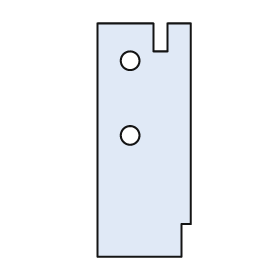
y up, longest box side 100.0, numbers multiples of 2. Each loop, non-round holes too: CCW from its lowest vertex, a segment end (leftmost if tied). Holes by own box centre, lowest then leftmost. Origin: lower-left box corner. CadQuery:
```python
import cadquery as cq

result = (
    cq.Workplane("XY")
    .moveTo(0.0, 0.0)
    .lineTo(36.0, 0.0)
    .lineTo(36.0, 14.0)
    .lineTo(40.0, 14.0)
    .lineTo(40.0, 100.0)
    .lineTo(30.0, 100.0)
    .lineTo(30.0, 88.0)
    .lineTo(24.0, 88.0)
    .lineTo(24.0, 100.0)
    .lineTo(0.0, 100.0)
    .close()
    .moveTo(14.0, 52.0)
    .circle(4.0)
    .moveTo(14.0, 84.0)
    .circle(4.0)
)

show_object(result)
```